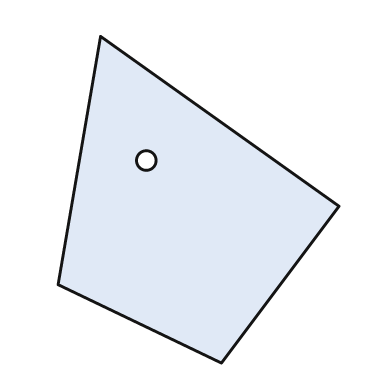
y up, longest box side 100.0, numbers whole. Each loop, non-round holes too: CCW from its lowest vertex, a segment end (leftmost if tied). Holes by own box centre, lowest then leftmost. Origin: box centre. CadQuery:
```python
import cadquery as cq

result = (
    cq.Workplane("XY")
    .moveTo(7.0, -50.0)
    .lineTo(43.0, -2.0)
    .lineTo(-30.0, 50.0)
    .lineTo(-43.0, -26.0)
    .close()
    .moveTo(-16.0, 12.0)
    .circle(3.0)
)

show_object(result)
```